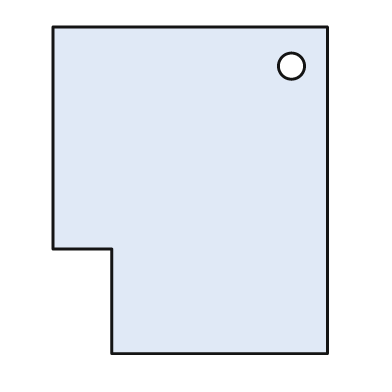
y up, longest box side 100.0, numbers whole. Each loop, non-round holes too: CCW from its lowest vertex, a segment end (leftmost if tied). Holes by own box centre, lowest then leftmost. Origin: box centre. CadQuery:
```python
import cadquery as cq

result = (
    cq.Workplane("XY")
    .moveTo(-24.0, -50.0)
    .lineTo(42.0, -50.0)
    .lineTo(42.0, 50.0)
    .lineTo(-42.0, 50.0)
    .lineTo(-42.0, -18.0)
    .lineTo(-24.0, -18.0)
    .close()
    .moveTo(31.0, 38.0)
    .circle(4.0)
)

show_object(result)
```